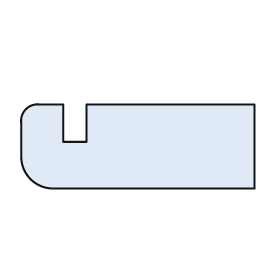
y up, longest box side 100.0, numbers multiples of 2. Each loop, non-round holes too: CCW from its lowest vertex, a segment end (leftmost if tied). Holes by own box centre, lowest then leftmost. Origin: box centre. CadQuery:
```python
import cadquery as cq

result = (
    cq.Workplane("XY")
    .moveTo(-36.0, -18.0)
    .lineTo(50.0, -18.0)
    .lineTo(50.0, 18.0)
    .lineTo(-22.0, 18.0)
    .lineTo(-22.0, 2.0)
    .lineTo(-32.0, 2.0)
    .lineTo(-32.0, 18.0)
    .lineTo(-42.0, 18.0)
    .threePointArc((-48.0, 16.0), (-50.0, 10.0))
    .lineTo(-50.0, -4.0)
    .threePointArc((-46.0, -14.0), (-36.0, -18.0))
    .close()
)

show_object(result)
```